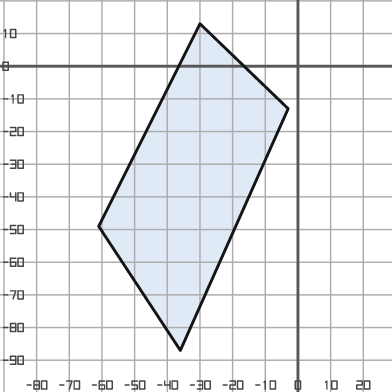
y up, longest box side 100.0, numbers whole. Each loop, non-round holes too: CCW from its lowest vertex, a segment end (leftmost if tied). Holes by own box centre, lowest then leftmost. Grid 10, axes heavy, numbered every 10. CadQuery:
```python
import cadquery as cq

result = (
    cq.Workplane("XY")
    .moveTo(-36.0, -87.0)
    .lineTo(-3.0, -13.0)
    .lineTo(-30.0, 13.0)
    .lineTo(-61.0, -49.0)
    .close()
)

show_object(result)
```